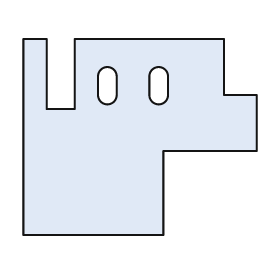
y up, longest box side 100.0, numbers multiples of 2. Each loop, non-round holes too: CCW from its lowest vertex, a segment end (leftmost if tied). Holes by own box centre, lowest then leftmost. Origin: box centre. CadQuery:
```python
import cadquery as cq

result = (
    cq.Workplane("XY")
    .moveTo(-50.0, -42.0)
    .lineTo(10.0, -42.0)
    .lineTo(10.0, -6.0)
    .lineTo(50.0, -6.0)
    .lineTo(50.0, 18.0)
    .lineTo(36.0, 18.0)
    .lineTo(36.0, 42.0)
    .lineTo(-28.0, 42.0)
    .lineTo(-28.0, 12.0)
    .lineTo(-40.0, 12.0)
    .lineTo(-40.0, 42.0)
    .lineTo(-50.0, 42.0)
    .close()
    .moveTo(-18.0, 18.0)
    .threePointArc((-14.0, 14.0), (-10.0, 18.0))
    .lineTo(-10.0, 26.0)
    .threePointArc((-14.0, 30.0), (-18.0, 26.0))
    .close()
    .moveTo(4.0, 18.0)
    .threePointArc((8.0, 14.0), (12.0, 18.0))
    .lineTo(12.0, 26.0)
    .threePointArc((8.0, 30.0), (4.0, 26.0))
    .close()
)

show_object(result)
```